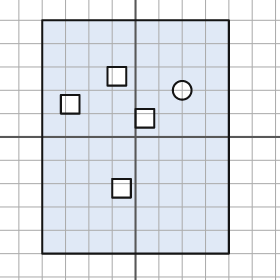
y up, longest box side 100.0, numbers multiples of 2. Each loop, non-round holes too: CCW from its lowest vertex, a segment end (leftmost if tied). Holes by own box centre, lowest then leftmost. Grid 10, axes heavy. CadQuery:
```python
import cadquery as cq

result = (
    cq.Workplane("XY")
    .moveTo(-40.0, -50.0)
    .lineTo(40.0, -50.0)
    .lineTo(40.0, 50.0)
    .lineTo(-40.0, 50.0)
    .close()
    .moveTo(-10.0, -26.0)
    .lineTo(-2.0, -26.0)
    .lineTo(-2.0, -18.0)
    .lineTo(-10.0, -18.0)
    .close()
    .moveTo(0.0, 4.0)
    .lineTo(8.0, 4.0)
    .lineTo(8.0, 12.0)
    .lineTo(0.0, 12.0)
    .close()
    .moveTo(-32.0, 10.0)
    .lineTo(-24.0, 10.0)
    .lineTo(-24.0, 18.0)
    .lineTo(-32.0, 18.0)
    .close()
    .moveTo(20.0, 20.0)
    .circle(4.0)
    .moveTo(-12.0, 22.0)
    .lineTo(-4.0, 22.0)
    .lineTo(-4.0, 30.0)
    .lineTo(-12.0, 30.0)
    .close()
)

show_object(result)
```